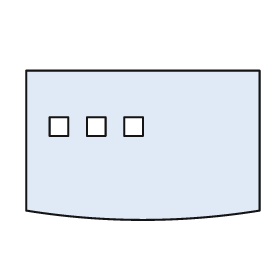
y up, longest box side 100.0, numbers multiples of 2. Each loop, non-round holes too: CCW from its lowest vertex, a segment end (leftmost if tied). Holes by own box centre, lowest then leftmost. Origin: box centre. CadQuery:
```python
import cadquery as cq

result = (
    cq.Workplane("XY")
    .moveTo(-50.0, -28.0)
    .threePointArc((0.0, -32.0), (50.0, -28.0))
    .lineTo(50.0, 32.0)
    .lineTo(-50.0, 32.0)
    .close()
    .moveTo(-40.0, 4.0)
    .lineTo(-32.0, 4.0)
    .lineTo(-32.0, 12.0)
    .lineTo(-40.0, 12.0)
    .close()
    .moveTo(-24.0, 4.0)
    .lineTo(-16.0, 4.0)
    .lineTo(-16.0, 12.0)
    .lineTo(-24.0, 12.0)
    .close()
    .moveTo(-8.0, 4.0)
    .lineTo(0.0, 4.0)
    .lineTo(0.0, 12.0)
    .lineTo(-8.0, 12.0)
    .close()
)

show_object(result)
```